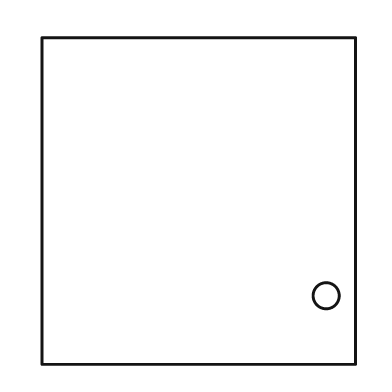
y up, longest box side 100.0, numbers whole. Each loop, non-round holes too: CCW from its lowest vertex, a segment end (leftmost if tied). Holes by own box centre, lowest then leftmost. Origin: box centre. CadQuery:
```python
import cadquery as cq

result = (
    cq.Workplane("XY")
    .moveTo(-48.0, -50.0)
    .lineTo(48.0, -50.0)
    .lineTo(48.0, 50.0)
    .lineTo(-48.0, 50.0)
    .close()
    .moveTo(39.0, -29.0)
    .circle(4.0)
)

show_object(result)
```